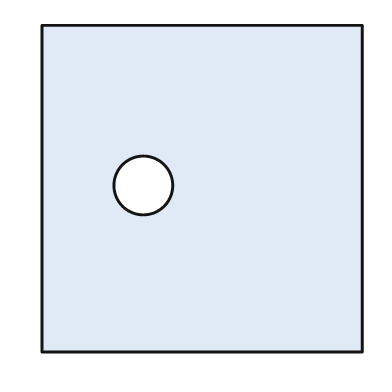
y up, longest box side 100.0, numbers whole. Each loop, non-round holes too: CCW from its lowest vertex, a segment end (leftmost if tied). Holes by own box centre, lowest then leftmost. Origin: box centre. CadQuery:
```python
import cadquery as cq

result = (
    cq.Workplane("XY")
    .moveTo(-49.0, -50.0)
    .lineTo(49.0, -50.0)
    .lineTo(49.0, 50.0)
    .lineTo(-49.0, 50.0)
    .close()
    .moveTo(-18.0, 1.0)
    .circle(9.0)
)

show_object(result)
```